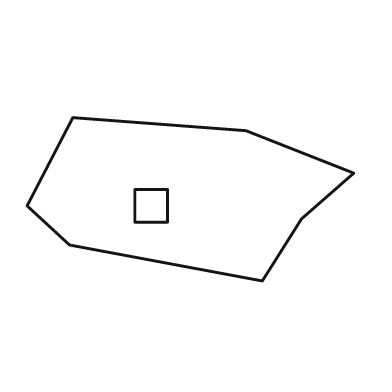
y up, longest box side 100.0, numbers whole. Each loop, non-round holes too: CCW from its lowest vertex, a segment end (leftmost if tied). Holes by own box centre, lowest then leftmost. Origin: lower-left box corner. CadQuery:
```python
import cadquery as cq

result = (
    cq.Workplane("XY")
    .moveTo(72.0, 0.0)
    .lineTo(84.0, 19.0)
    .lineTo(100.0, 33.0)
    .lineTo(67.0, 46.0)
    .lineTo(14.0, 50.0)
    .lineTo(0.0, 23.0)
    .lineTo(13.0, 11.0)
    .close()
    .moveTo(33.0, 18.0)
    .lineTo(43.0, 18.0)
    .lineTo(43.0, 28.0)
    .lineTo(33.0, 28.0)
    .close()
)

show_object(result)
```